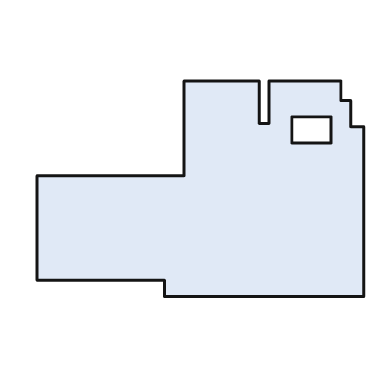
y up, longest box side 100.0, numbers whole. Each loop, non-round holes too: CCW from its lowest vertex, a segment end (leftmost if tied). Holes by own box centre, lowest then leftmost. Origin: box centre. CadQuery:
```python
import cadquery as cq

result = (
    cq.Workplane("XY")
    .moveTo(-11.0, -33.0)
    .lineTo(50.0, -33.0)
    .lineTo(50.0, 19.0)
    .lineTo(46.0, 19.0)
    .lineTo(46.0, 27.0)
    .lineTo(43.0, 27.0)
    .lineTo(43.0, 33.0)
    .lineTo(21.0, 33.0)
    .lineTo(21.0, 20.0)
    .lineTo(18.0, 20.0)
    .lineTo(18.0, 33.0)
    .lineTo(-5.0, 33.0)
    .lineTo(-5.0, 4.0)
    .lineTo(-50.0, 4.0)
    .lineTo(-50.0, -28.0)
    .lineTo(-11.0, -28.0)
    .close()
    .moveTo(28.0, 14.0)
    .lineTo(40.0, 14.0)
    .lineTo(40.0, 22.0)
    .lineTo(28.0, 22.0)
    .close()
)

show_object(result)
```